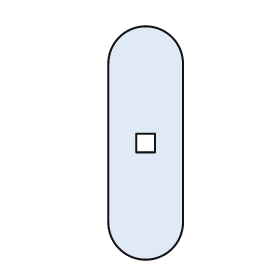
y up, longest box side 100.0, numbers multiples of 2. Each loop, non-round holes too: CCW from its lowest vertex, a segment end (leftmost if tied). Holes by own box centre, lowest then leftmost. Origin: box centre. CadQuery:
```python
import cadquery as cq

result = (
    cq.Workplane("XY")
    .moveTo(-16.0, -34.0)
    .threePointArc((0.0, -50.0), (16.0, -34.0))
    .lineTo(16.0, 34.0)
    .threePointArc((0.0, 50.0), (-16.0, 34.0))
    .close()
    .moveTo(-4.0, -4.0)
    .lineTo(4.0, -4.0)
    .lineTo(4.0, 4.0)
    .lineTo(-4.0, 4.0)
    .close()
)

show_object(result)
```